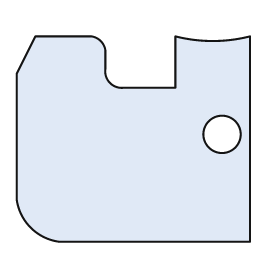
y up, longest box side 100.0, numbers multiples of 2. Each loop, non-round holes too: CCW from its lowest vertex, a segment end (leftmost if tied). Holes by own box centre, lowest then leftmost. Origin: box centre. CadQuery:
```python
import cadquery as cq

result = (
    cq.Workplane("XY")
    .moveTo(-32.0, -44.0)
    .lineTo(50.0, -44.0)
    .lineTo(50.0, 44.0)
    .threePointArc((34.0, 42.0), (18.0, 44.0))
    .lineTo(18.0, 22.0)
    .lineTo(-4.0, 22.0)
    .threePointArc((-10.0, 24.0), (-12.0, 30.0))
    .lineTo(-12.0, 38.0)
    .threePointArc((-14.0, 42.0), (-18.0, 44.0))
    .lineTo(-42.0, 44.0)
    .lineTo(-50.0, 28.0)
    .lineTo(-50.0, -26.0)
    .threePointArc((-44.0, -38.0), (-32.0, -44.0))
    .close()
    .moveTo(38.0, 2.0)
    .circle(8.0)
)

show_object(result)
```